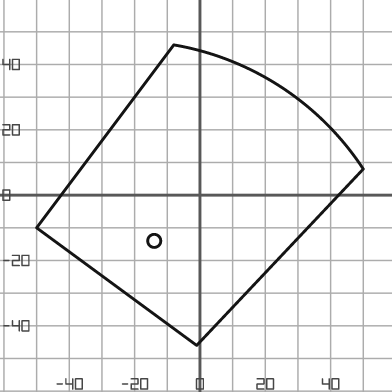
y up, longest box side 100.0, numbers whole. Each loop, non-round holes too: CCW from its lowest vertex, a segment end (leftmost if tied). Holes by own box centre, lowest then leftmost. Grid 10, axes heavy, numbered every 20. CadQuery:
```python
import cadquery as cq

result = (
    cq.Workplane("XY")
    .moveTo(-1.0, -46.0)
    .lineTo(50.0, 8.0)
    .threePointArc((25.0, 33.0), (-8.0, 46.0))
    .lineTo(-50.0, -10.0)
    .close()
    .moveTo(-14.0, -14.0)
    .circle(2.0)
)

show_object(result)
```